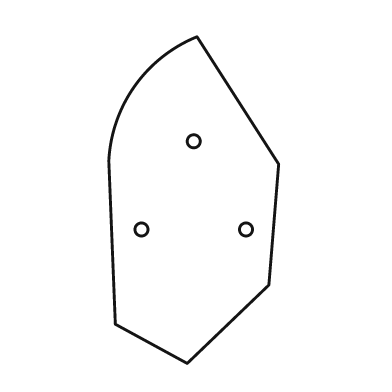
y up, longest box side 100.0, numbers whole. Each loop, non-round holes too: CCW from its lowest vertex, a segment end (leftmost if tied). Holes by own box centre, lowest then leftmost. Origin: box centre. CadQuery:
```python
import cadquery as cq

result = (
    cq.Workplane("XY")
    .moveTo(-2.0, -50.0)
    .lineTo(23.0, -26.0)
    .lineTo(26.0, 11.0)
    .lineTo(1.0, 50.0)
    .threePointArc((-18.0, 35.0), (-26.0, 12.0))
    .lineTo(-24.0, -38.0)
    .close()
    .moveTo(-16.0, -9.0)
    .circle(2.0)
    .moveTo(16.0, -9.0)
    .circle(2.0)
    .moveTo(0.0, 18.0)
    .circle(2.0)
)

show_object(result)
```